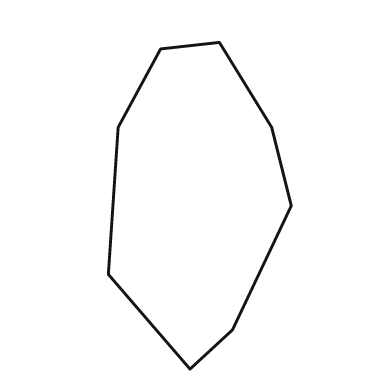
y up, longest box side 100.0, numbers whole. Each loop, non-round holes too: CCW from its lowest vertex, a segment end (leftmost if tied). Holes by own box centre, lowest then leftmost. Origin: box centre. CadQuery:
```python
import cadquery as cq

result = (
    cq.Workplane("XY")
    .moveTo(-3.0, -50.0)
    .lineTo(10.0, -38.0)
    .lineTo(28.0, 0.0)
    .lineTo(22.0, 24.0)
    .lineTo(6.0, 50.0)
    .lineTo(-12.0, 48.0)
    .lineTo(-25.0, 24.0)
    .lineTo(-28.0, -21.0)
    .close()
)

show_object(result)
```